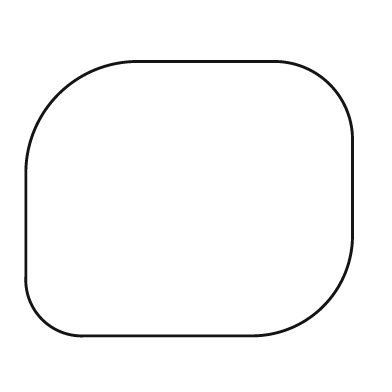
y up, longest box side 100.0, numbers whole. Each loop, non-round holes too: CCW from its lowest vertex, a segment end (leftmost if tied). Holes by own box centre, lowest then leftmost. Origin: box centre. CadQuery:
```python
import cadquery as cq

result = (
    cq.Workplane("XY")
    .moveTo(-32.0, -42.0)
    .lineTo(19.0, -42.0)
    .threePointArc((41.0, -33.0), (50.0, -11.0))
    .lineTo(50.0, 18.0)
    .threePointArc((43.0, 35.0), (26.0, 42.0))
    .lineTo(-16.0, 42.0)
    .threePointArc((-40.0, 32.0), (-50.0, 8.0))
    .lineTo(-50.0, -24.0)
    .threePointArc((-45.0, -37.0), (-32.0, -42.0))
    .close()
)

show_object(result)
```